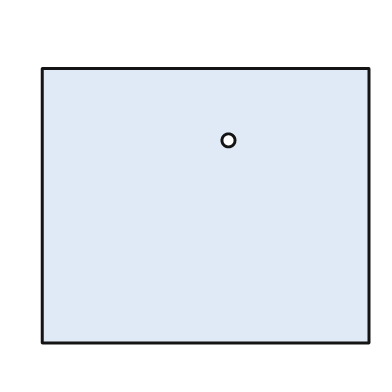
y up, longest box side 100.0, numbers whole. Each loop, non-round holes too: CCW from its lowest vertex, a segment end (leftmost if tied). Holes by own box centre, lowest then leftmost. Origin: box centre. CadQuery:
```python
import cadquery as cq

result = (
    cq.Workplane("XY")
    .moveTo(-50.0, -42.0)
    .lineTo(50.0, -42.0)
    .lineTo(50.0, 42.0)
    .lineTo(-50.0, 42.0)
    .close()
    .moveTo(7.0, 20.0)
    .circle(2.0)
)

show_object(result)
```